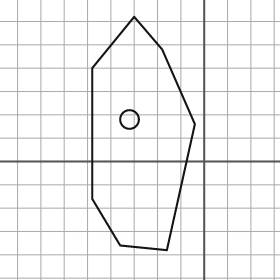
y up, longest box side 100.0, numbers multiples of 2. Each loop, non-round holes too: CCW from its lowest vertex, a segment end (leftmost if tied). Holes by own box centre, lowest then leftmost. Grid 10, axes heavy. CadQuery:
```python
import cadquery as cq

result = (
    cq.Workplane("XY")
    .moveTo(-16.0, -38.0)
    .lineTo(-4.0, 16.0)
    .lineTo(-18.0, 48.0)
    .lineTo(-30.0, 62.0)
    .lineTo(-48.0, 40.0)
    .lineTo(-48.0, -16.0)
    .lineTo(-36.0, -36.0)
    .close()
    .moveTo(-32.0, 18.0)
    .circle(4.0)
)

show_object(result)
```